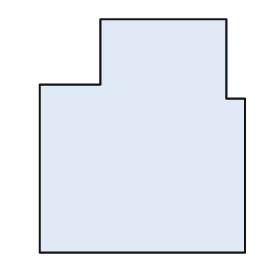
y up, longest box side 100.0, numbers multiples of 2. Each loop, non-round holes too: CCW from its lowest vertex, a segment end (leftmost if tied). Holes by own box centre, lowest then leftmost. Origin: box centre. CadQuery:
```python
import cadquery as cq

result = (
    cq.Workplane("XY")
    .moveTo(-44.0, -50.0)
    .lineTo(44.0, -50.0)
    .lineTo(44.0, 16.0)
    .lineTo(36.0, 16.0)
    .lineTo(36.0, 50.0)
    .lineTo(-18.0, 50.0)
    .lineTo(-18.0, 22.0)
    .lineTo(-44.0, 22.0)
    .close()
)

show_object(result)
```